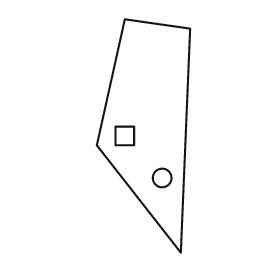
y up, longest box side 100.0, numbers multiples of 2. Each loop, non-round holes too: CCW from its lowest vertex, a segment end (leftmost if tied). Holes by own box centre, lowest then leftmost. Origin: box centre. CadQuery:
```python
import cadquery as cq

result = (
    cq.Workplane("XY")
    .moveTo(16.0, -50.0)
    .lineTo(20.0, 46.0)
    .lineTo(-8.0, 50.0)
    .lineTo(-20.0, -4.0)
    .close()
    .moveTo(8.0, -18.0)
    .circle(4.0)
    .moveTo(-12.0, -4.0)
    .lineTo(-4.0, -4.0)
    .lineTo(-4.0, 4.0)
    .lineTo(-12.0, 4.0)
    .close()
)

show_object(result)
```